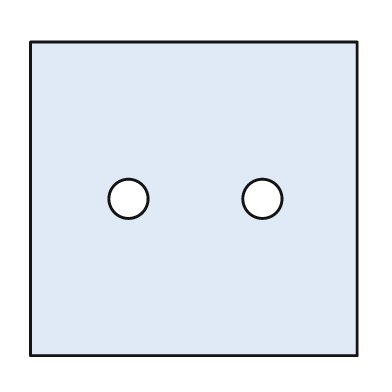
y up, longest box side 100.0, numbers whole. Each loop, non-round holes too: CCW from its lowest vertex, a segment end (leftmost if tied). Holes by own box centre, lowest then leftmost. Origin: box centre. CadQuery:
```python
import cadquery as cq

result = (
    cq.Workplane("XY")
    .moveTo(-50.0, -48.0)
    .lineTo(50.0, -48.0)
    .lineTo(50.0, 48.0)
    .lineTo(-50.0, 48.0)
    .close()
    .moveTo(-20.0, 0.0)
    .circle(6.0)
    .moveTo(21.0, 0.0)
    .circle(6.0)
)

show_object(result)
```